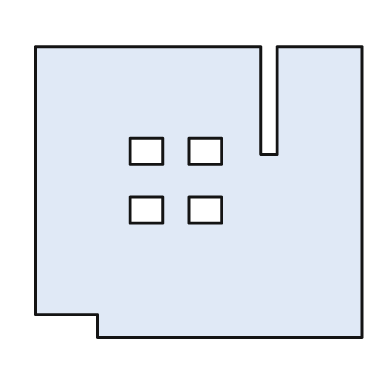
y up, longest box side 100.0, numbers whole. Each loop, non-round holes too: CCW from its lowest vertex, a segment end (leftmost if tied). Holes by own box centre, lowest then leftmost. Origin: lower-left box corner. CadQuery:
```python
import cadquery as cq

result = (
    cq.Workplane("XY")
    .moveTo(19.0, 0.0)
    .lineTo(100.0, 0.0)
    .lineTo(100.0, 89.0)
    .lineTo(74.0, 89.0)
    .lineTo(74.0, 56.0)
    .lineTo(69.0, 56.0)
    .lineTo(69.0, 89.0)
    .lineTo(0.0, 89.0)
    .lineTo(0.0, 7.0)
    .lineTo(19.0, 7.0)
    .close()
    .moveTo(29.0, 35.0)
    .lineTo(39.0, 35.0)
    .lineTo(39.0, 43.0)
    .lineTo(29.0, 43.0)
    .close()
    .moveTo(47.0, 35.0)
    .lineTo(57.0, 35.0)
    .lineTo(57.0, 43.0)
    .lineTo(47.0, 43.0)
    .close()
    .moveTo(29.0, 53.0)
    .lineTo(39.0, 53.0)
    .lineTo(39.0, 61.0)
    .lineTo(29.0, 61.0)
    .close()
    .moveTo(47.0, 53.0)
    .lineTo(57.0, 53.0)
    .lineTo(57.0, 61.0)
    .lineTo(47.0, 61.0)
    .close()
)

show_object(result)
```